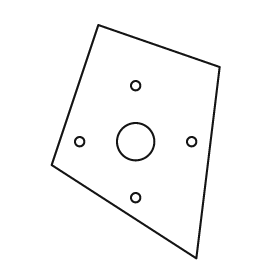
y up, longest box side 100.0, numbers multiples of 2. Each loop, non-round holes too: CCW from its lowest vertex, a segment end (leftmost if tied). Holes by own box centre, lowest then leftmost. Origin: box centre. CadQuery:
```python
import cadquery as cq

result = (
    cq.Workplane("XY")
    .moveTo(26.0, -50.0)
    .lineTo(36.0, 32.0)
    .lineTo(-16.0, 50.0)
    .lineTo(-36.0, -10.0)
    .close()
    .moveTo(0.0, -24.0)
    .circle(2.0)
    .moveTo(-24.0, 0.0)
    .circle(2.0)
    .moveTo(0.0, 0.0)
    .circle(8.0)
    .moveTo(24.0, 0.0)
    .circle(2.0)
    .moveTo(0.0, 24.0)
    .circle(2.0)
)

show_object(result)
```